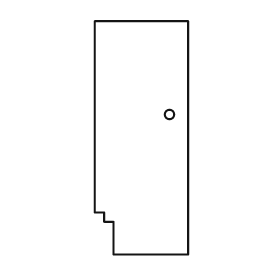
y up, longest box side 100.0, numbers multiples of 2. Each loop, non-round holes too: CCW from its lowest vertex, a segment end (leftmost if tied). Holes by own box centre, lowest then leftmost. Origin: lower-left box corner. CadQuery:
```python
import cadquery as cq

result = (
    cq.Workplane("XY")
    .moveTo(8.0, 0.0)
    .lineTo(40.0, 0.0)
    .lineTo(40.0, 100.0)
    .lineTo(0.0, 100.0)
    .lineTo(0.0, 18.0)
    .lineTo(4.0, 18.0)
    .lineTo(4.0, 14.0)
    .lineTo(8.0, 14.0)
    .close()
    .moveTo(32.0, 60.0)
    .circle(2.0)
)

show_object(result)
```